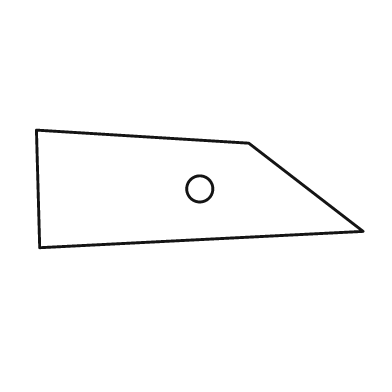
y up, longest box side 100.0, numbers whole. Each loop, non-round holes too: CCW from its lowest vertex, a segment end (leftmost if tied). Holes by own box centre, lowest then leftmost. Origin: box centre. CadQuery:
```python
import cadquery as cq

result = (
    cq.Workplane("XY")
    .moveTo(-49.0, -18.0)
    .lineTo(50.0, -13.0)
    .lineTo(15.0, 14.0)
    .lineTo(-50.0, 18.0)
    .close()
    .moveTo(0.0, 0.0)
    .circle(4.0)
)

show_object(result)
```